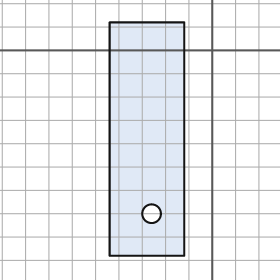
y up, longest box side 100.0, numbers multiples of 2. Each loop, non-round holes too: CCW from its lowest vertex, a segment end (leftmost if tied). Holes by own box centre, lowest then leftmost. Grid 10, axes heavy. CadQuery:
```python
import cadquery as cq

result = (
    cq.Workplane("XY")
    .moveTo(-44.0, -88.0)
    .lineTo(-12.0, -88.0)
    .lineTo(-12.0, 12.0)
    .lineTo(-44.0, 12.0)
    .close()
    .moveTo(-26.0, -70.0)
    .circle(4.0)
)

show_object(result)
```